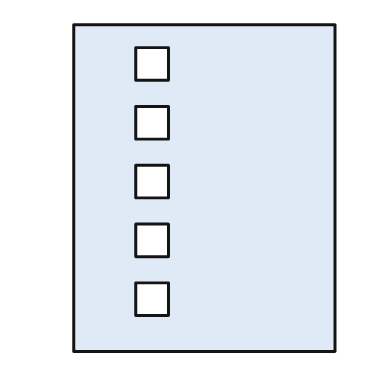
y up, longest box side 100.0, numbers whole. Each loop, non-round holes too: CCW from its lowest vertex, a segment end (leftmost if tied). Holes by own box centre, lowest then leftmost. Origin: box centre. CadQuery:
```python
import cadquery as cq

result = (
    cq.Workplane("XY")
    .moveTo(-40.0, -50.0)
    .lineTo(40.0, -50.0)
    .lineTo(40.0, 50.0)
    .lineTo(-40.0, 50.0)
    .close()
    .moveTo(-21.0, -39.0)
    .lineTo(-11.0, -39.0)
    .lineTo(-11.0, -29.0)
    .lineTo(-21.0, -29.0)
    .close()
    .moveTo(-21.0, -21.0)
    .lineTo(-11.0, -21.0)
    .lineTo(-11.0, -11.0)
    .lineTo(-21.0, -11.0)
    .close()
    .moveTo(-21.0, -3.0)
    .lineTo(-11.0, -3.0)
    .lineTo(-11.0, 7.0)
    .lineTo(-21.0, 7.0)
    .close()
    .moveTo(-21.0, 15.0)
    .lineTo(-11.0, 15.0)
    .lineTo(-11.0, 25.0)
    .lineTo(-21.0, 25.0)
    .close()
    .moveTo(-21.0, 33.0)
    .lineTo(-11.0, 33.0)
    .lineTo(-11.0, 43.0)
    .lineTo(-21.0, 43.0)
    .close()
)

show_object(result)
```